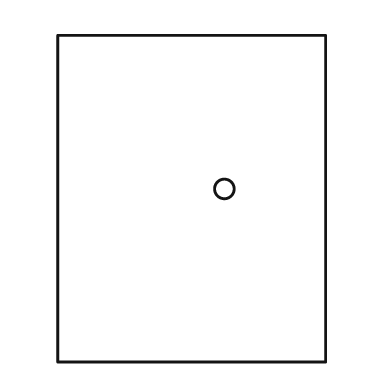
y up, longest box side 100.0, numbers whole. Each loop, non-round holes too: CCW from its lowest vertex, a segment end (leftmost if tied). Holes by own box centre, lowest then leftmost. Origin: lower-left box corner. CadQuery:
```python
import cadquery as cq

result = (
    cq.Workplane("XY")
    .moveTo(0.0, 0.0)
    .lineTo(82.0, 0.0)
    .lineTo(82.0, 100.0)
    .lineTo(0.0, 100.0)
    .close()
    .moveTo(51.0, 53.0)
    .circle(3.0)
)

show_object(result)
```